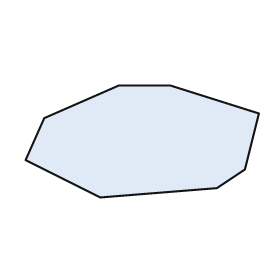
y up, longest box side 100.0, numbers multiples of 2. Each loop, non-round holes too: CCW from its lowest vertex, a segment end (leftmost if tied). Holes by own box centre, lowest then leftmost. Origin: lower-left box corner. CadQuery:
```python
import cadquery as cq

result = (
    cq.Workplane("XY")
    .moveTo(32.0, 0.0)
    .lineTo(82.0, 4.0)
    .lineTo(94.0, 12.0)
    .lineTo(100.0, 36.0)
    .lineTo(62.0, 48.0)
    .lineTo(40.0, 48.0)
    .lineTo(8.0, 34.0)
    .lineTo(0.0, 16.0)
    .close()
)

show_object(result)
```